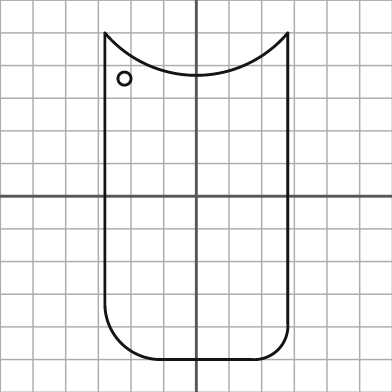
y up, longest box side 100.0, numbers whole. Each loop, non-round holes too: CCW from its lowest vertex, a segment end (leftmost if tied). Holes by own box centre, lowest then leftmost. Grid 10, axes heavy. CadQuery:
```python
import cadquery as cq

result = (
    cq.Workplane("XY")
    .moveTo(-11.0, -50.0)
    .lineTo(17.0, -50.0)
    .threePointArc((25.0, -47.0), (28.0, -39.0))
    .lineTo(28.0, 50.0)
    .threePointArc((0.0, 37.0), (-28.0, 50.0))
    .lineTo(-28.0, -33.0)
    .threePointArc((-23.0, -45.0), (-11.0, -50.0))
    .close()
    .moveTo(-22.0, 36.0)
    .circle(2.0)
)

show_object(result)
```